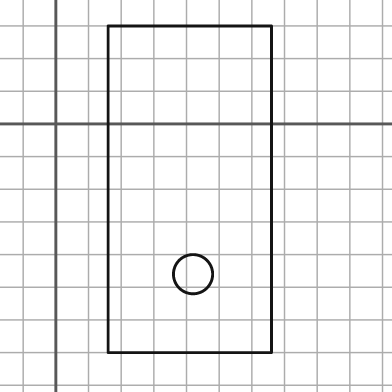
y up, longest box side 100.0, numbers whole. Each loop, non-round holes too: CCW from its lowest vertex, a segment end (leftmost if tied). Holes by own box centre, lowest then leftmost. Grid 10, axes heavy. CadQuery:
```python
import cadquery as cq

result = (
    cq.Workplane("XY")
    .moveTo(16.0, -70.0)
    .lineTo(66.0, -70.0)
    .lineTo(66.0, 30.0)
    .lineTo(16.0, 30.0)
    .close()
    .moveTo(42.0, -46.0)
    .circle(6.0)
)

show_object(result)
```